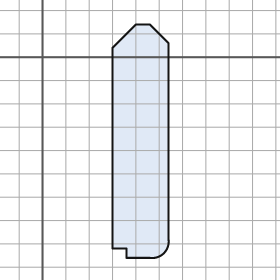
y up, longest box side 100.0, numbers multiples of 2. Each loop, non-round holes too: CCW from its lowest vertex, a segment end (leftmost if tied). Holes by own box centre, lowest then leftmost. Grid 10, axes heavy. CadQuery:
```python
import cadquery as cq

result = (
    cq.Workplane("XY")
    .moveTo(36.0, -86.0)
    .lineTo(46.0, -86.0)
    .threePointArc((52.0, -84.0), (54.0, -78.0))
    .lineTo(54.0, 6.0)
    .lineTo(46.0, 14.0)
    .lineTo(40.0, 14.0)
    .lineTo(30.0, 4.0)
    .lineTo(30.0, -82.0)
    .lineTo(36.0, -82.0)
    .close()
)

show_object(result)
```